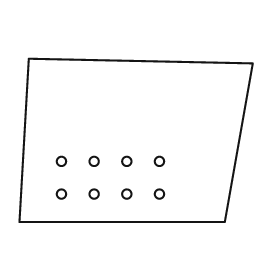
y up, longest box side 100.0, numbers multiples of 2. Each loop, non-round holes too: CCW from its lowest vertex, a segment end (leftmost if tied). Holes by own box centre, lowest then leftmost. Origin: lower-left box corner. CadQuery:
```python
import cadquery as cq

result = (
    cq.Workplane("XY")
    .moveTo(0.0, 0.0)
    .lineTo(88.0, 0.0)
    .lineTo(100.0, 68.0)
    .lineTo(4.0, 70.0)
    .close()
    .moveTo(18.0, 12.0)
    .circle(2.0)
    .moveTo(32.0, 12.0)
    .circle(2.0)
    .moveTo(46.0, 12.0)
    .circle(2.0)
    .moveTo(60.0, 12.0)
    .circle(2.0)
    .moveTo(18.0, 26.0)
    .circle(2.0)
    .moveTo(32.0, 26.0)
    .circle(2.0)
    .moveTo(46.0, 26.0)
    .circle(2.0)
    .moveTo(60.0, 26.0)
    .circle(2.0)
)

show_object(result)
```